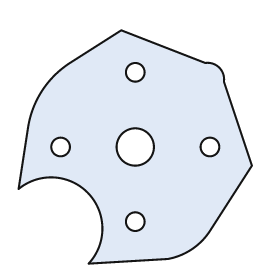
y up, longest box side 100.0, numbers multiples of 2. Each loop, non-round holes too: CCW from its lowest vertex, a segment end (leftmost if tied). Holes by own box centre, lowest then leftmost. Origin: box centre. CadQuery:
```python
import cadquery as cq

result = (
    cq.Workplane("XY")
    .moveTo(-20.0, -50.0)
    .lineTo(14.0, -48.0)
    .threePointArc((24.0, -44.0), (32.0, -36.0))
    .lineTo(50.0, -8.0)
    .lineTo(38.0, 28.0)
    .threePointArc((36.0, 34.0), (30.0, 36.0))
    .lineTo(-6.0, 50.0)
    .lineTo(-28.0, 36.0)
    .threePointArc((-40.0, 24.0), (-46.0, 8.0))
    .lineTo(-50.0, -18.0)
    .threePointArc((-20.0, -20.0), (-20.0, -50.0))
    .close()
    .moveTo(0.0, -32.0)
    .circle(4.0)
    .moveTo(-32.0, 0.0)
    .circle(4.0)
    .moveTo(0.0, 0.0)
    .circle(8.0)
    .moveTo(32.0, 0.0)
    .circle(4.0)
    .moveTo(0.0, 32.0)
    .circle(4.0)
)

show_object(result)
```